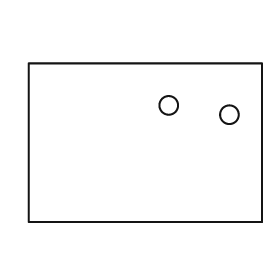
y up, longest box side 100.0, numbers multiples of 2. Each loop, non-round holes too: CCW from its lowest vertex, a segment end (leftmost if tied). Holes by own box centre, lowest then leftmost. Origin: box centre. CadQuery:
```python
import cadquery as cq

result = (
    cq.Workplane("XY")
    .moveTo(-50.0, -34.0)
    .lineTo(50.0, -34.0)
    .lineTo(50.0, 34.0)
    .lineTo(-50.0, 34.0)
    .close()
    .moveTo(36.0, 12.0)
    .circle(4.0)
    .moveTo(10.0, 16.0)
    .circle(4.0)
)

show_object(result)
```